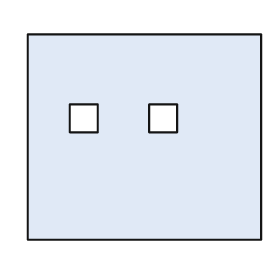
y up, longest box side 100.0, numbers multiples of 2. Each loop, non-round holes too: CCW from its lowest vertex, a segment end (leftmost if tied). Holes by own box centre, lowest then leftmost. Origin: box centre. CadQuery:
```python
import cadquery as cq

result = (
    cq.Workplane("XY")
    .moveTo(-50.0, -44.0)
    .lineTo(50.0, -44.0)
    .lineTo(50.0, 44.0)
    .lineTo(-50.0, 44.0)
    .close()
    .moveTo(-32.0, 2.0)
    .lineTo(-20.0, 2.0)
    .lineTo(-20.0, 14.0)
    .lineTo(-32.0, 14.0)
    .close()
    .moveTo(2.0, 2.0)
    .lineTo(14.0, 2.0)
    .lineTo(14.0, 14.0)
    .lineTo(2.0, 14.0)
    .close()
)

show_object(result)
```